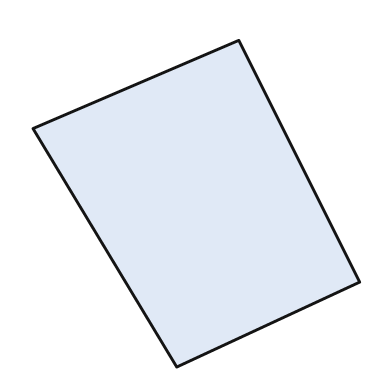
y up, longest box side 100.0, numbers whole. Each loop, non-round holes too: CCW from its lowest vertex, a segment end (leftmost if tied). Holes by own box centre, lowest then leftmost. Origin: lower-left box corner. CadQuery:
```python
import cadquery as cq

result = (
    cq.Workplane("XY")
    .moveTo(44.0, 0.0)
    .lineTo(100.0, 26.0)
    .lineTo(63.0, 100.0)
    .lineTo(0.0, 73.0)
    .close()
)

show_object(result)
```